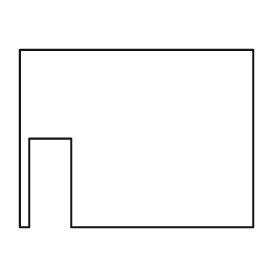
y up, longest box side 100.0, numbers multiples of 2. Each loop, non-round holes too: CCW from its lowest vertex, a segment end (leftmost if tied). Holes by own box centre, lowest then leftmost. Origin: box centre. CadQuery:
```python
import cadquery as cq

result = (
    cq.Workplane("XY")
    .moveTo(-50.0, -38.0)
    .lineTo(-46.0, -38.0)
    .lineTo(-46.0, 0.0)
    .lineTo(-28.0, 0.0)
    .lineTo(-28.0, -38.0)
    .lineTo(50.0, -38.0)
    .lineTo(50.0, 38.0)
    .lineTo(-50.0, 38.0)
    .close()
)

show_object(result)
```